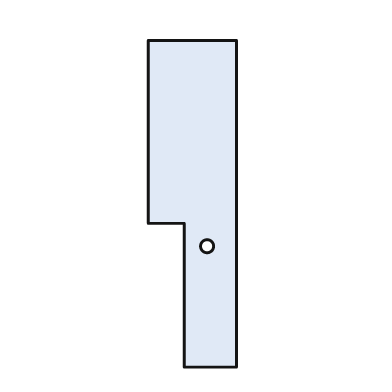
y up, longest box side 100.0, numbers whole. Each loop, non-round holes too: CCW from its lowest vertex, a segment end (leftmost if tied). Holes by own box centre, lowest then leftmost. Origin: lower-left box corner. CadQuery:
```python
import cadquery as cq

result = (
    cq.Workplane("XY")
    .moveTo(11.0, 0.0)
    .lineTo(27.0, 0.0)
    .lineTo(27.0, 100.0)
    .lineTo(0.0, 100.0)
    .lineTo(0.0, 44.0)
    .lineTo(11.0, 44.0)
    .close()
    .moveTo(18.0, 37.0)
    .circle(2.0)
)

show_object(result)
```